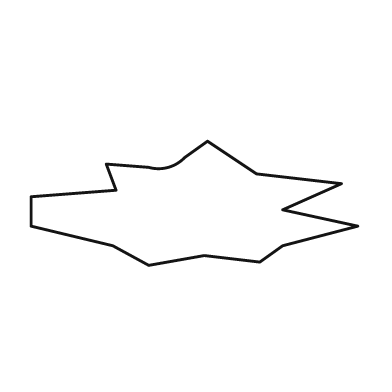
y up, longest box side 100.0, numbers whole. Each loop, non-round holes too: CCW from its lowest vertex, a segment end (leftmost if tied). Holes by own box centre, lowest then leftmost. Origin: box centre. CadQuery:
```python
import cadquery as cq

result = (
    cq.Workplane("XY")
    .moveTo(-14.0, -19.0)
    .lineTo(3.0, -16.0)
    .lineTo(20.0, -18.0)
    .lineTo(27.0, -13.0)
    .lineTo(50.0, -7.0)
    .lineTo(27.0, -2.0)
    .lineTo(45.0, 6.0)
    .lineTo(19.0, 9.0)
    .lineTo(4.0, 19.0)
    .lineTo(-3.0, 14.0)
    .threePointArc((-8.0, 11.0), (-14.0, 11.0))
    .lineTo(-27.0, 12.0)
    .lineTo(-24.0, 4.0)
    .lineTo(-50.0, 2.0)
    .lineTo(-50.0, -7.0)
    .lineTo(-25.0, -13.0)
    .close()
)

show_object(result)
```